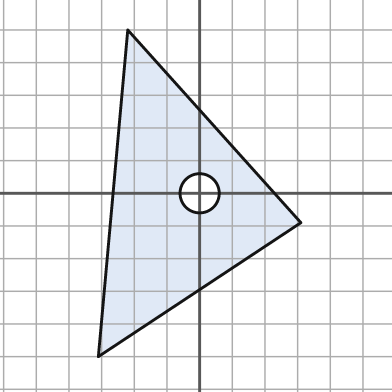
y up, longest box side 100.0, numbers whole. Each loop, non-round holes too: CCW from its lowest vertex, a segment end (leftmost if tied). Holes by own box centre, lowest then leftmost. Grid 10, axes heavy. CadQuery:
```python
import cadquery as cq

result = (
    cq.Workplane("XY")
    .moveTo(-31.0, -50.0)
    .lineTo(31.0, -9.0)
    .lineTo(-22.0, 50.0)
    .close()
    .moveTo(0.0, 0.0)
    .circle(6.0)
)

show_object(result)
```